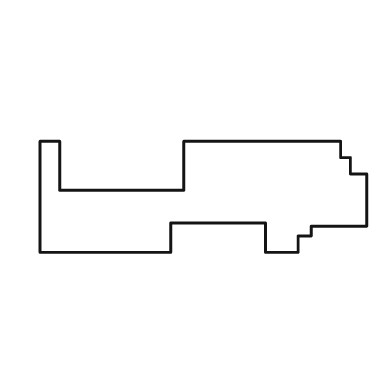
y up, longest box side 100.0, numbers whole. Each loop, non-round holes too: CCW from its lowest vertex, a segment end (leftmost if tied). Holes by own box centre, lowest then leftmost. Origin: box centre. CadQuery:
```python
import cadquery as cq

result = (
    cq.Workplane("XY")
    .moveTo(-50.0, -17.0)
    .lineTo(-10.0, -17.0)
    .lineTo(-10.0, -8.0)
    .lineTo(19.0, -8.0)
    .lineTo(19.0, -17.0)
    .lineTo(29.0, -17.0)
    .lineTo(29.0, -12.0)
    .lineTo(33.0, -12.0)
    .lineTo(33.0, -9.0)
    .lineTo(50.0, -9.0)
    .lineTo(50.0, 7.0)
    .lineTo(45.0, 7.0)
    .lineTo(45.0, 12.0)
    .lineTo(42.0, 12.0)
    .lineTo(42.0, 17.0)
    .lineTo(-6.0, 17.0)
    .lineTo(-6.0, 2.0)
    .lineTo(-44.0, 2.0)
    .lineTo(-44.0, 17.0)
    .lineTo(-50.0, 17.0)
    .close()
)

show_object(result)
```